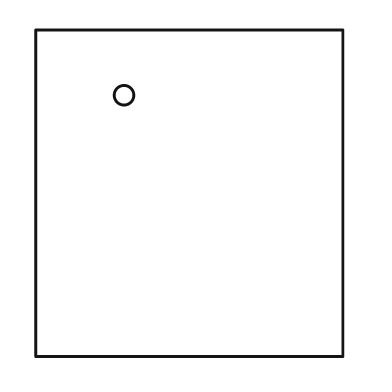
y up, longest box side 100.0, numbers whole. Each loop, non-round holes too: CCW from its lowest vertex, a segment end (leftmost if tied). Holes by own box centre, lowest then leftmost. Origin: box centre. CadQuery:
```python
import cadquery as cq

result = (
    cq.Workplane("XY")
    .moveTo(-47.0, -50.0)
    .lineTo(47.0, -50.0)
    .lineTo(47.0, 50.0)
    .lineTo(-47.0, 50.0)
    .close()
    .moveTo(-20.0, 30.0)
    .circle(3.0)
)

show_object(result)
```